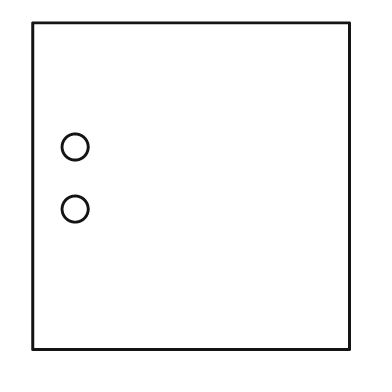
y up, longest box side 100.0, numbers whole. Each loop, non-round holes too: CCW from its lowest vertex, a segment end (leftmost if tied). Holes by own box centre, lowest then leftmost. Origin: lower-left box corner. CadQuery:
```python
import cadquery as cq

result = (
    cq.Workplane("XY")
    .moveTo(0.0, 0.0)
    .lineTo(97.0, 0.0)
    .lineTo(97.0, 100.0)
    .lineTo(0.0, 100.0)
    .close()
    .moveTo(13.0, 43.0)
    .circle(4.0)
    .moveTo(13.0, 62.0)
    .circle(4.0)
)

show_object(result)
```